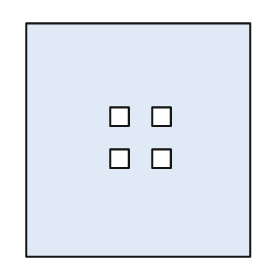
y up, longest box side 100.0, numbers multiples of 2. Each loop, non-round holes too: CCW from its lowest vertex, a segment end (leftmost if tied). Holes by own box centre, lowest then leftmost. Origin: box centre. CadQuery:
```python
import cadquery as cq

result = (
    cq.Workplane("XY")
    .moveTo(-48.0, -50.0)
    .lineTo(48.0, -50.0)
    .lineTo(48.0, 50.0)
    .lineTo(-48.0, 50.0)
    .close()
    .moveTo(-12.0, -12.0)
    .lineTo(-4.0, -12.0)
    .lineTo(-4.0, -4.0)
    .lineTo(-12.0, -4.0)
    .close()
    .moveTo(6.0, -12.0)
    .lineTo(14.0, -12.0)
    .lineTo(14.0, -4.0)
    .lineTo(6.0, -4.0)
    .close()
    .moveTo(-12.0, 6.0)
    .lineTo(-4.0, 6.0)
    .lineTo(-4.0, 14.0)
    .lineTo(-12.0, 14.0)
    .close()
    .moveTo(6.0, 6.0)
    .lineTo(14.0, 6.0)
    .lineTo(14.0, 14.0)
    .lineTo(6.0, 14.0)
    .close()
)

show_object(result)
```